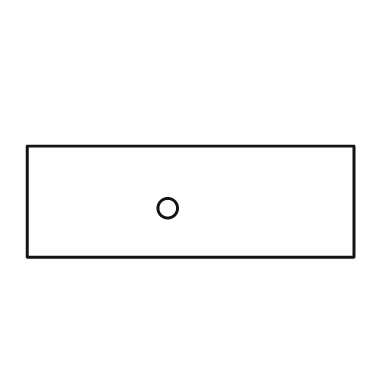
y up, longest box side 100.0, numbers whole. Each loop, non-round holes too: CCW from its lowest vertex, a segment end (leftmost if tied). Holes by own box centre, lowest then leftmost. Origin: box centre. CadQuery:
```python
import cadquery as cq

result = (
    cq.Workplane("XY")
    .moveTo(-50.0, -17.0)
    .lineTo(50.0, -17.0)
    .lineTo(50.0, 17.0)
    .lineTo(-50.0, 17.0)
    .close()
    .moveTo(-7.0, -2.0)
    .circle(3.0)
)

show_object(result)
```